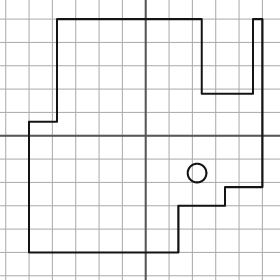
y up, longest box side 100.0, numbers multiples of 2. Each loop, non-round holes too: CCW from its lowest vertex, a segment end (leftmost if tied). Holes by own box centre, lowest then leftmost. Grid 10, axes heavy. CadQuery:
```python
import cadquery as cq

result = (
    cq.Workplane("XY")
    .moveTo(-50.0, -50.0)
    .lineTo(14.0, -50.0)
    .lineTo(14.0, -30.0)
    .lineTo(34.0, -30.0)
    .lineTo(34.0, -22.0)
    .lineTo(50.0, -22.0)
    .lineTo(50.0, 50.0)
    .lineTo(46.0, 50.0)
    .lineTo(46.0, 18.0)
    .lineTo(24.0, 18.0)
    .lineTo(24.0, 50.0)
    .lineTo(-38.0, 50.0)
    .lineTo(-38.0, 6.0)
    .lineTo(-50.0, 6.0)
    .close()
    .moveTo(22.0, -16.0)
    .circle(4.0)
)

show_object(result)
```